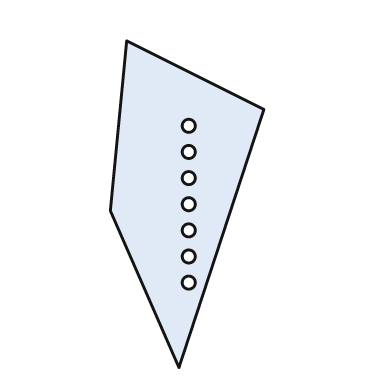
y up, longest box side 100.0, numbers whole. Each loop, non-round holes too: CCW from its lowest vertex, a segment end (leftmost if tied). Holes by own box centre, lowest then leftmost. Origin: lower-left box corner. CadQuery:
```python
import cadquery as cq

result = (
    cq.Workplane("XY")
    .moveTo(21.0, 0.0)
    .lineTo(47.0, 79.0)
    .lineTo(5.0, 100.0)
    .lineTo(0.0, 48.0)
    .close()
    .moveTo(24.0, 26.0)
    .circle(2.0)
    .moveTo(24.0, 34.0)
    .circle(2.0)
    .moveTo(24.0, 42.0)
    .circle(2.0)
    .moveTo(24.0, 50.0)
    .circle(2.0)
    .moveTo(24.0, 58.0)
    .circle(2.0)
    .moveTo(24.0, 66.0)
    .circle(2.0)
    .moveTo(24.0, 74.0)
    .circle(2.0)
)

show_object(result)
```